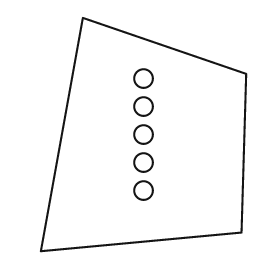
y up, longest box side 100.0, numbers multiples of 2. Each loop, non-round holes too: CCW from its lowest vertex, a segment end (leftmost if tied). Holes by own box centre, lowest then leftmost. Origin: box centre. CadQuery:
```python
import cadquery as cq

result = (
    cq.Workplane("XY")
    .moveTo(-44.0, -50.0)
    .lineTo(42.0, -42.0)
    .lineTo(44.0, 26.0)
    .lineTo(-26.0, 50.0)
    .close()
    .moveTo(0.0, -24.0)
    .circle(4.0)
    .moveTo(0.0, -12.0)
    .circle(4.0)
    .moveTo(0.0, 0.0)
    .circle(4.0)
    .moveTo(0.0, 12.0)
    .circle(4.0)
    .moveTo(0.0, 24.0)
    .circle(4.0)
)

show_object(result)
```